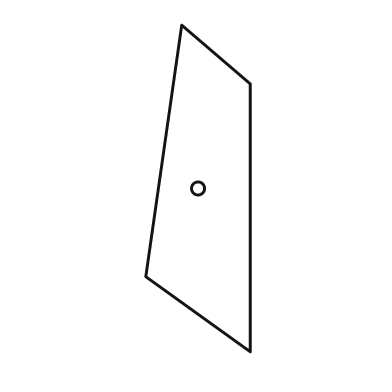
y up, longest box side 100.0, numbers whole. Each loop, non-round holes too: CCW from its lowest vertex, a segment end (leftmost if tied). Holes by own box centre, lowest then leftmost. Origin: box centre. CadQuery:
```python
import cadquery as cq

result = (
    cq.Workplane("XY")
    .moveTo(16.0, -50.0)
    .lineTo(16.0, 32.0)
    .lineTo(-5.0, 50.0)
    .lineTo(-16.0, -27.0)
    .close()
    .moveTo(0.0, 0.0)
    .circle(2.0)
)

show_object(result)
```